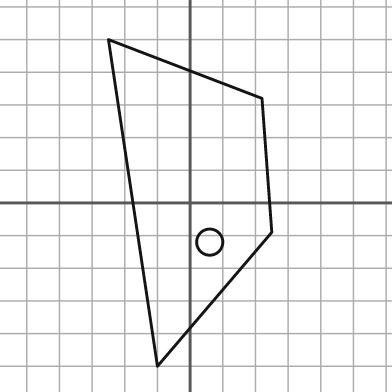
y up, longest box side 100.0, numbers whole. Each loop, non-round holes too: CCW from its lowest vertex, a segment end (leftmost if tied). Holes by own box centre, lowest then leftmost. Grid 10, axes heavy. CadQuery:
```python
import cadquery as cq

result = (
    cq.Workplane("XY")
    .moveTo(-10.0, -50.0)
    .lineTo(25.0, -9.0)
    .lineTo(22.0, 32.0)
    .lineTo(-25.0, 50.0)
    .close()
    .moveTo(6.0, -12.0)
    .circle(4.0)
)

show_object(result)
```